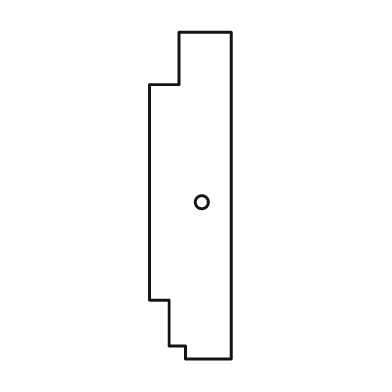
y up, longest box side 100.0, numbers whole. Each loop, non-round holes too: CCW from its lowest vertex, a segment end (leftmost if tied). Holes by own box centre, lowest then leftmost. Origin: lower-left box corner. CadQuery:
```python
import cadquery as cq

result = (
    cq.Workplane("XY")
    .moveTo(11.0, 0.0)
    .lineTo(25.0, 0.0)
    .lineTo(25.0, 100.0)
    .lineTo(9.0, 100.0)
    .lineTo(9.0, 84.0)
    .lineTo(0.0, 84.0)
    .lineTo(0.0, 18.0)
    .lineTo(6.0, 18.0)
    .lineTo(6.0, 4.0)
    .lineTo(11.0, 4.0)
    .close()
    .moveTo(16.0, 48.0)
    .circle(2.0)
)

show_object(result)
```